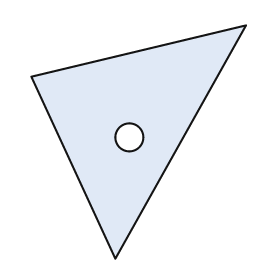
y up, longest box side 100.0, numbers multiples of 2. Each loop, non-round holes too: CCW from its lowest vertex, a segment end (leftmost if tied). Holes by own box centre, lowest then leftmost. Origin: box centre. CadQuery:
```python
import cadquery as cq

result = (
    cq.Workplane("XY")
    .moveTo(-10.0, -50.0)
    .lineTo(46.0, 50.0)
    .lineTo(-46.0, 28.0)
    .close()
    .moveTo(-4.0, 2.0)
    .circle(6.0)
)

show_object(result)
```